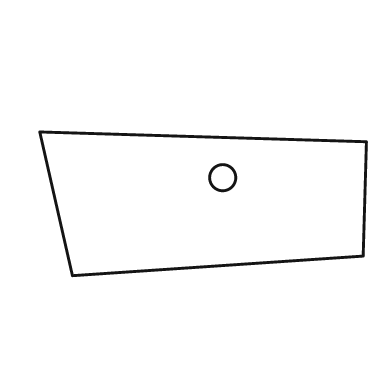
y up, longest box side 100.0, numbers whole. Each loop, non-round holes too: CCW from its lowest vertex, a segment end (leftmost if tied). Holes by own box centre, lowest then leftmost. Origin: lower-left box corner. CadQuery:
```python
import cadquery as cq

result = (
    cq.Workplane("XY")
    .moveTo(10.0, 0.0)
    .lineTo(99.0, 6.0)
    .lineTo(100.0, 41.0)
    .lineTo(0.0, 44.0)
    .close()
    .moveTo(56.0, 30.0)
    .circle(4.0)
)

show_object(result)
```